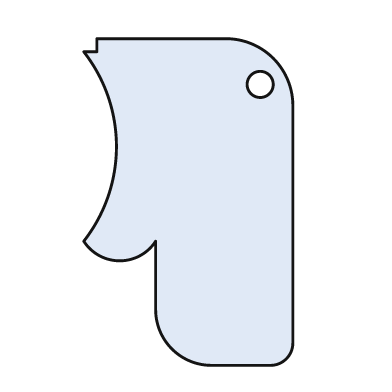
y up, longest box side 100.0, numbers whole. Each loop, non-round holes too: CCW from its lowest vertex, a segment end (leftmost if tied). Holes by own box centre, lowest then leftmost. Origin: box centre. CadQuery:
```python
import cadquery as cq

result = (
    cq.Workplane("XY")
    .moveTo(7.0, -50.0)
    .lineTo(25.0, -50.0)
    .threePointArc((30.0, -48.0), (32.0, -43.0))
    .lineTo(32.0, 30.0)
    .threePointArc((26.0, 44.0), (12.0, 50.0))
    .lineTo(-28.0, 50.0)
    .lineTo(-28.0, 46.0)
    .lineTo(-32.0, 46.0)
    .threePointArc((-22.0, 17.0), (-32.0, -12.0))
    .threePointArc((-21.0, -18.0), (-10.0, -12.0))
    .lineTo(-10.0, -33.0)
    .threePointArc((-5.0, -45.0), (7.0, -50.0))
    .close()
    .moveTo(22.0, 36.0)
    .circle(4.0)
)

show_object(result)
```